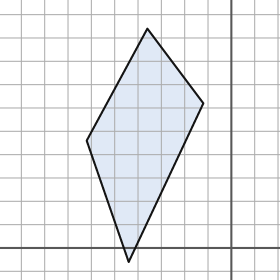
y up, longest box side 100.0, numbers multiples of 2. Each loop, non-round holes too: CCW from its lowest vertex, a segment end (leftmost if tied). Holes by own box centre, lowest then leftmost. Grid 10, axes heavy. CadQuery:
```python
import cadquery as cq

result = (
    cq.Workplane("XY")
    .moveTo(-44.0, -6.0)
    .lineTo(-12.0, 62.0)
    .lineTo(-36.0, 94.0)
    .lineTo(-62.0, 46.0)
    .close()
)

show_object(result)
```